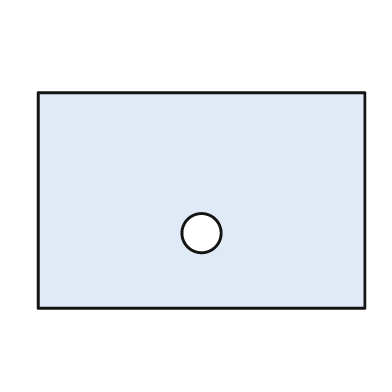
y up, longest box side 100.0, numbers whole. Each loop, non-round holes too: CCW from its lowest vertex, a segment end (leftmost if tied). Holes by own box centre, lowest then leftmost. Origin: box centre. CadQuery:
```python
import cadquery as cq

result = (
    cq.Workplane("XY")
    .moveTo(-50.0, -33.0)
    .lineTo(50.0, -33.0)
    .lineTo(50.0, 33.0)
    .lineTo(-50.0, 33.0)
    .close()
    .moveTo(0.0, -10.0)
    .circle(6.0)
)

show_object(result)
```